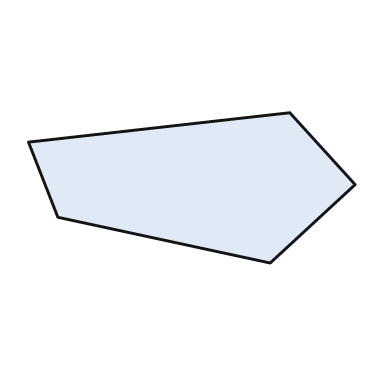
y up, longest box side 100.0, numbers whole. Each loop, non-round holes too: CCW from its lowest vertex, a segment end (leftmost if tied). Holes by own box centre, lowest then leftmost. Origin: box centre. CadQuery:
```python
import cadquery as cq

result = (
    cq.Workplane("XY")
    .moveTo(24.0, -23.0)
    .lineTo(50.0, 1.0)
    .lineTo(30.0, 23.0)
    .lineTo(-50.0, 14.0)
    .lineTo(-41.0, -9.0)
    .close()
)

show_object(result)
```